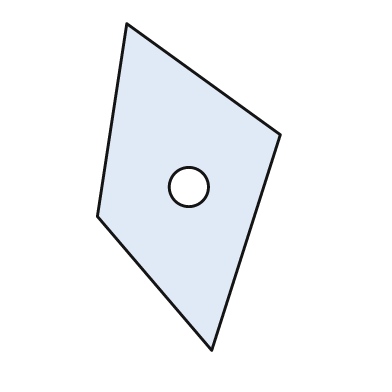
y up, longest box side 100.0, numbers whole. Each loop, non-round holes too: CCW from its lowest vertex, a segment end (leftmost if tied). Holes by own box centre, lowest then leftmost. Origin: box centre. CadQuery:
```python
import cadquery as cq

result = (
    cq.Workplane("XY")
    .moveTo(7.0, -50.0)
    .lineTo(28.0, 16.0)
    .lineTo(-19.0, 50.0)
    .lineTo(-28.0, -9.0)
    .close()
    .moveTo(0.0, 0.0)
    .circle(6.0)
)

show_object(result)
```